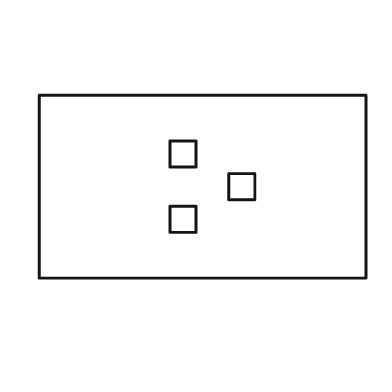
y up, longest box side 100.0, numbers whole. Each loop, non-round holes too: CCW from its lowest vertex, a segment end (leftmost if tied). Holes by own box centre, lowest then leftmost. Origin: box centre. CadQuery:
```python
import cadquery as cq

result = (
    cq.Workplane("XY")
    .moveTo(-50.0, -28.0)
    .lineTo(50.0, -28.0)
    .lineTo(50.0, 28.0)
    .lineTo(-50.0, 28.0)
    .close()
    .moveTo(-10.0, -14.0)
    .lineTo(-2.0, -14.0)
    .lineTo(-2.0, -6.0)
    .lineTo(-10.0, -6.0)
    .close()
    .moveTo(8.0, -4.0)
    .lineTo(16.0, -4.0)
    .lineTo(16.0, 4.0)
    .lineTo(8.0, 4.0)
    .close()
    .moveTo(-10.0, 6.0)
    .lineTo(-2.0, 6.0)
    .lineTo(-2.0, 14.0)
    .lineTo(-10.0, 14.0)
    .close()
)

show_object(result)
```